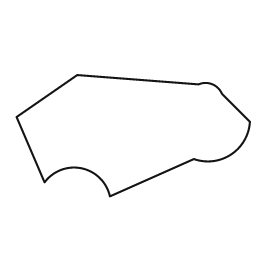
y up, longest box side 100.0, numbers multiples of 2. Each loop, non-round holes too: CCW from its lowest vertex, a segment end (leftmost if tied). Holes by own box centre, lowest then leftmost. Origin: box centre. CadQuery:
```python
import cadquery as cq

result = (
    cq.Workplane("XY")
    .moveTo(-10.0, -26.0)
    .lineTo(26.0, -10.0)
    .threePointArc((42.0, -8.0), (50.0, 6.0))
    .lineTo(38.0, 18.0)
    .threePointArc((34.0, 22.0), (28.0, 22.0))
    .lineTo(-24.0, 26.0)
    .lineTo(-50.0, 8.0)
    .lineTo(-38.0, -20.0)
    .threePointArc((-22.0, -14.0), (-10.0, -26.0))
    .close()
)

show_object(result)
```